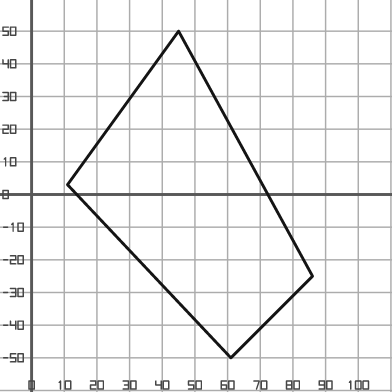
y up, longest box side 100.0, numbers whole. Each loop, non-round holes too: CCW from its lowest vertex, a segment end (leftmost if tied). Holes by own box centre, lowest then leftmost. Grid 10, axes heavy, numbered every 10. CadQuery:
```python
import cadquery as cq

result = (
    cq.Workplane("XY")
    .moveTo(61.0, -50.0)
    .lineTo(86.0, -25.0)
    .lineTo(45.0, 50.0)
    .lineTo(11.0, 3.0)
    .close()
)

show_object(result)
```